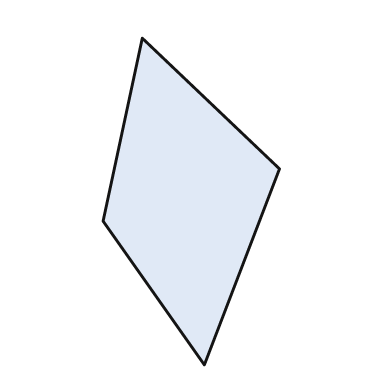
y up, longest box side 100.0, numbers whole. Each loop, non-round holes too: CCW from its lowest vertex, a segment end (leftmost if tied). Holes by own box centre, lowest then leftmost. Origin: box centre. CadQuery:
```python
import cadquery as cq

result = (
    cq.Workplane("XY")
    .moveTo(4.0, -50.0)
    .lineTo(27.0, 10.0)
    .lineTo(-15.0, 50.0)
    .lineTo(-27.0, -6.0)
    .close()
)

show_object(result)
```